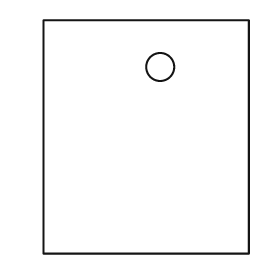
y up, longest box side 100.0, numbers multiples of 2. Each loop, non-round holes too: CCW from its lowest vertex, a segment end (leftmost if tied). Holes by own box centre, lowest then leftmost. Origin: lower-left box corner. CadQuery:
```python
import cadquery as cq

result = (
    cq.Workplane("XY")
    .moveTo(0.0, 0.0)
    .lineTo(88.0, 0.0)
    .lineTo(88.0, 100.0)
    .lineTo(0.0, 100.0)
    .close()
    .moveTo(50.0, 80.0)
    .circle(6.0)
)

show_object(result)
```